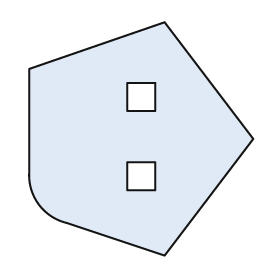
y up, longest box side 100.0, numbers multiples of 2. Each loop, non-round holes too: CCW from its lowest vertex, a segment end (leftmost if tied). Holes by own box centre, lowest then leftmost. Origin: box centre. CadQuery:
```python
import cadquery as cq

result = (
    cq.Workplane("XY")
    .moveTo(10.0, -50.0)
    .lineTo(48.0, 0.0)
    .lineTo(10.0, 50.0)
    .lineTo(-48.0, 30.0)
    .lineTo(-48.0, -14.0)
    .threePointArc((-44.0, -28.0), (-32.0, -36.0))
    .close()
    .moveTo(-6.0, -22.0)
    .lineTo(6.0, -22.0)
    .lineTo(6.0, -10.0)
    .lineTo(-6.0, -10.0)
    .close()
    .moveTo(-6.0, 12.0)
    .lineTo(6.0, 12.0)
    .lineTo(6.0, 24.0)
    .lineTo(-6.0, 24.0)
    .close()
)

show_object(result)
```